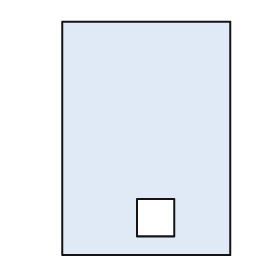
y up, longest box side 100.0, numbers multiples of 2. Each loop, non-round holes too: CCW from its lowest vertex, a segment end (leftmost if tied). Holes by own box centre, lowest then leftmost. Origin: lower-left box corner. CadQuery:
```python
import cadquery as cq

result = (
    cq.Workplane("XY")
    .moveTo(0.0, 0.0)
    .lineTo(72.0, 0.0)
    .lineTo(72.0, 100.0)
    .lineTo(0.0, 100.0)
    .close()
    .moveTo(32.0, 8.0)
    .lineTo(48.0, 8.0)
    .lineTo(48.0, 24.0)
    .lineTo(32.0, 24.0)
    .close()
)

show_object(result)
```